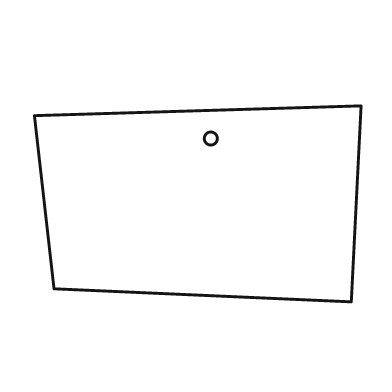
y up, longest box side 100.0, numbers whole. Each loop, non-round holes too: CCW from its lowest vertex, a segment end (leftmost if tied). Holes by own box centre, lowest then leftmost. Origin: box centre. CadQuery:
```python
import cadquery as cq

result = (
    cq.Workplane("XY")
    .moveTo(47.0, -30.0)
    .lineTo(50.0, 30.0)
    .lineTo(-50.0, 27.0)
    .lineTo(-44.0, -26.0)
    .close()
    .moveTo(4.0, 20.0)
    .circle(2.0)
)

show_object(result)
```